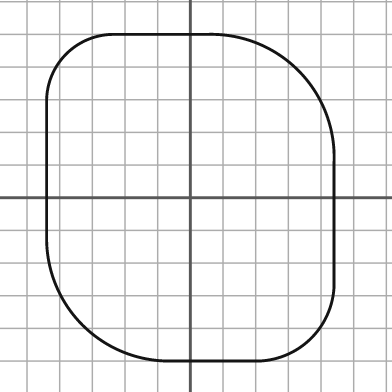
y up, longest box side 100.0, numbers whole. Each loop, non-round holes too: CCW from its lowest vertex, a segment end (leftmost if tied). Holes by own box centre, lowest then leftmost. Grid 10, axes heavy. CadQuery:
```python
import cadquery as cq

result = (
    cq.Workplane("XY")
    .moveTo(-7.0, -50.0)
    .lineTo(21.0, -50.0)
    .threePointArc((37.0, -43.0), (44.0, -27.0))
    .lineTo(44.0, 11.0)
    .threePointArc((33.0, 39.0), (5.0, 50.0))
    .lineTo(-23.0, 50.0)
    .threePointArc((-38.0, 44.0), (-44.0, 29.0))
    .lineTo(-44.0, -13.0)
    .threePointArc((-33.0, -39.0), (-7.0, -50.0))
    .close()
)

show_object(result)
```